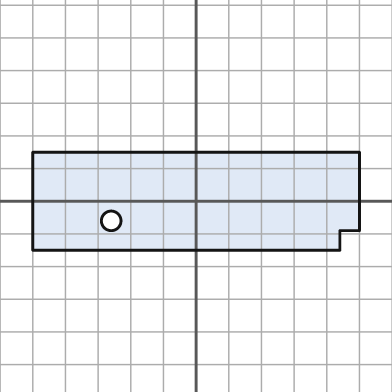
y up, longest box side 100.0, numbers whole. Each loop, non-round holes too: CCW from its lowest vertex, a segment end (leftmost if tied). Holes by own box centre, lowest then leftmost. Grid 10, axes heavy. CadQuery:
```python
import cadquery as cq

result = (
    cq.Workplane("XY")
    .moveTo(-50.0, -15.0)
    .lineTo(44.0, -15.0)
    .lineTo(44.0, -9.0)
    .lineTo(50.0, -9.0)
    .lineTo(50.0, 15.0)
    .lineTo(-50.0, 15.0)
    .close()
    .moveTo(-26.0, -6.0)
    .circle(3.0)
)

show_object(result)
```